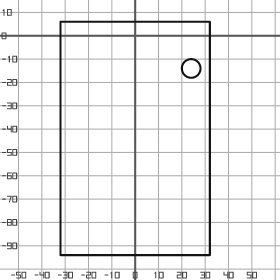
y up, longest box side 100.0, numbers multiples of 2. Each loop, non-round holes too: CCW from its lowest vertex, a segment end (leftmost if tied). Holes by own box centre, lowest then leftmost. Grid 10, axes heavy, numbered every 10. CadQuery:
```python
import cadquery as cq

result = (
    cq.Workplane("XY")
    .moveTo(-32.0, -94.0)
    .lineTo(32.0, -94.0)
    .lineTo(32.0, 6.0)
    .lineTo(-32.0, 6.0)
    .close()
    .moveTo(24.0, -14.0)
    .circle(4.0)
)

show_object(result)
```